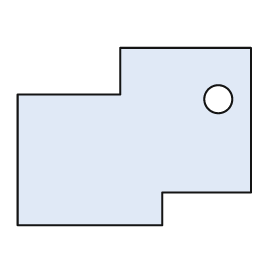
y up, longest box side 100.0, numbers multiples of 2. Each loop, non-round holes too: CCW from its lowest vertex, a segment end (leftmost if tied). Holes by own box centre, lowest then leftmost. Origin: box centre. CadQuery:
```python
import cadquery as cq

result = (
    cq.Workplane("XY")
    .moveTo(-50.0, -38.0)
    .lineTo(12.0, -38.0)
    .lineTo(12.0, -24.0)
    .lineTo(50.0, -24.0)
    .lineTo(50.0, 38.0)
    .lineTo(-6.0, 38.0)
    .lineTo(-6.0, 18.0)
    .lineTo(-50.0, 18.0)
    .close()
    .moveTo(36.0, 16.0)
    .circle(6.0)
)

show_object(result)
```